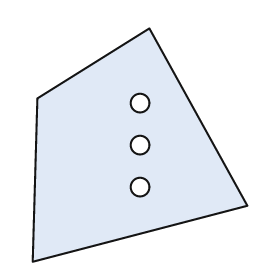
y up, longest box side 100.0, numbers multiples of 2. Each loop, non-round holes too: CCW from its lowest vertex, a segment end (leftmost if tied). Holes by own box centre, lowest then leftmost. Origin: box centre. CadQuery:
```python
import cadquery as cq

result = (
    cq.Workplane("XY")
    .moveTo(-46.0, -50.0)
    .lineTo(46.0, -26.0)
    .lineTo(4.0, 50.0)
    .lineTo(-44.0, 20.0)
    .close()
    .moveTo(0.0, -18.0)
    .circle(4.0)
    .moveTo(0.0, 0.0)
    .circle(4.0)
    .moveTo(0.0, 18.0)
    .circle(4.0)
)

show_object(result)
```